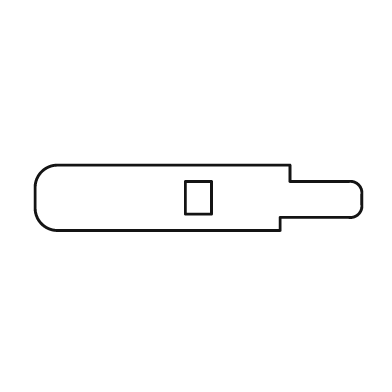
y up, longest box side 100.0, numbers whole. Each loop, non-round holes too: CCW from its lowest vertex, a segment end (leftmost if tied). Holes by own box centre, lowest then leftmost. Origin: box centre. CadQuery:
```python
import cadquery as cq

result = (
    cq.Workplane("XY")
    .moveTo(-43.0, -10.0)
    .lineTo(25.0, -10.0)
    .lineTo(25.0, -6.0)
    .lineTo(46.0, -6.0)
    .threePointArc((49.0, -5.0), (50.0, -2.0))
    .lineTo(50.0, 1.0)
    .threePointArc((49.0, 4.0), (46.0, 5.0))
    .lineTo(28.0, 5.0)
    .lineTo(28.0, 10.0)
    .lineTo(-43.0, 10.0)
    .threePointArc((-48.0, 8.0), (-50.0, 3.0))
    .lineTo(-50.0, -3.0)
    .threePointArc((-48.0, -8.0), (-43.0, -10.0))
    .close()
    .moveTo(-4.0, -5.0)
    .lineTo(4.0, -5.0)
    .lineTo(4.0, 5.0)
    .lineTo(-4.0, 5.0)
    .close()
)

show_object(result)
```